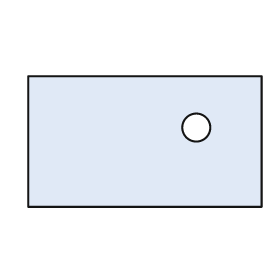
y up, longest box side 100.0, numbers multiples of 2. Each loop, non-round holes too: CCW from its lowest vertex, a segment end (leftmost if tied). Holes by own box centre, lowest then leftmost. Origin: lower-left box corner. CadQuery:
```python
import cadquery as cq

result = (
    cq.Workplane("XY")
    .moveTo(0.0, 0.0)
    .lineTo(100.0, 0.0)
    .lineTo(100.0, 56.0)
    .lineTo(0.0, 56.0)
    .close()
    .moveTo(72.0, 34.0)
    .circle(6.0)
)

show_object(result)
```